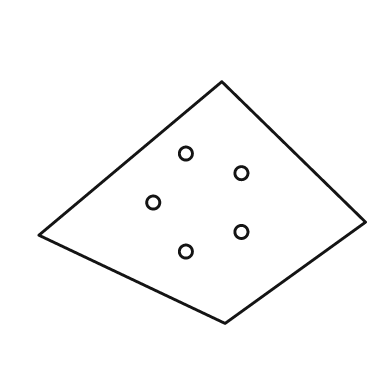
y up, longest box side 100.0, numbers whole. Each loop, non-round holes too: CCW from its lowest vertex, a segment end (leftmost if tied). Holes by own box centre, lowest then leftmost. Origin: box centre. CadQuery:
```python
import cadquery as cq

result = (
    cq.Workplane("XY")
    .moveTo(7.0, -37.0)
    .lineTo(50.0, -6.0)
    .lineTo(6.0, 37.0)
    .lineTo(-50.0, -10.0)
    .close()
    .moveTo(-5.0, -15.0)
    .circle(2.0)
    .moveTo(12.0, -9.0)
    .circle(2.0)
    .moveTo(-15.0, 0.0)
    .circle(2.0)
    .moveTo(12.0, 9.0)
    .circle(2.0)
    .moveTo(-5.0, 15.0)
    .circle(2.0)
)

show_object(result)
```